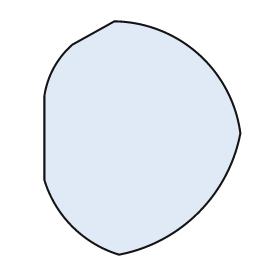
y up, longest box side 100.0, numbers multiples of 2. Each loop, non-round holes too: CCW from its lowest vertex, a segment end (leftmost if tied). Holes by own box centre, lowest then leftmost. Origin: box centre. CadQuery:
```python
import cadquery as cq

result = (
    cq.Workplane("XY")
    .moveTo(-10.0, -50.0)
    .threePointArc((24.0, -32.0), (42.0, 2.0))
    .threePointArc((24.0, 36.0), (-12.0, 50.0))
    .lineTo(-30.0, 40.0)
    .threePointArc((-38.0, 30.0), (-42.0, 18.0))
    .lineTo(-42.0, -18.0)
    .threePointArc((-30.0, -38.0), (-10.0, -50.0))
    .close()
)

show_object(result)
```